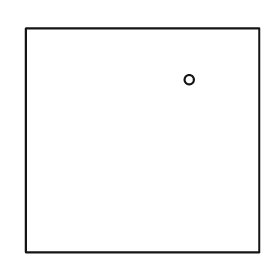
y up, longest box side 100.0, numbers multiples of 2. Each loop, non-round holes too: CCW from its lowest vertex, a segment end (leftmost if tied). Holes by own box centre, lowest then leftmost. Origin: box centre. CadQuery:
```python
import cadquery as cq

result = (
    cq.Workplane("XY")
    .moveTo(-50.0, -48.0)
    .lineTo(50.0, -48.0)
    .lineTo(50.0, 48.0)
    .lineTo(-50.0, 48.0)
    .close()
    .moveTo(20.0, 26.0)
    .circle(2.0)
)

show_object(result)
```